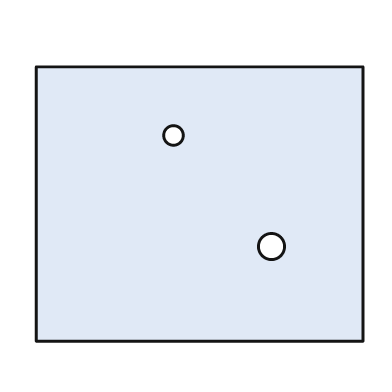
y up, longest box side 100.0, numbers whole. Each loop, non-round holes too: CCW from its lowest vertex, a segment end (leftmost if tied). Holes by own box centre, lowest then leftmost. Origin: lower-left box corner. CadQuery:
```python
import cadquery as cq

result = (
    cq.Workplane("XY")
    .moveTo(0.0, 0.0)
    .lineTo(100.0, 0.0)
    .lineTo(100.0, 84.0)
    .lineTo(0.0, 84.0)
    .close()
    .moveTo(72.0, 29.0)
    .circle(4.0)
    .moveTo(42.0, 63.0)
    .circle(3.0)
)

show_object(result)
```